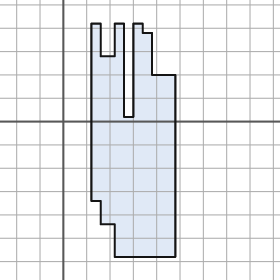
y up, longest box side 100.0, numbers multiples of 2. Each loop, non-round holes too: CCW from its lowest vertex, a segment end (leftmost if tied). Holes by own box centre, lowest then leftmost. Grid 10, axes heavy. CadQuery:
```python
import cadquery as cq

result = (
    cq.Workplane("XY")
    .moveTo(22.0, -58.0)
    .lineTo(48.0, -58.0)
    .lineTo(48.0, 20.0)
    .lineTo(38.0, 20.0)
    .lineTo(38.0, 38.0)
    .lineTo(34.0, 38.0)
    .lineTo(34.0, 42.0)
    .lineTo(30.0, 42.0)
    .lineTo(30.0, 2.0)
    .lineTo(26.0, 2.0)
    .lineTo(26.0, 42.0)
    .lineTo(22.0, 42.0)
    .lineTo(22.0, 28.0)
    .lineTo(16.0, 28.0)
    .lineTo(16.0, 42.0)
    .lineTo(12.0, 42.0)
    .lineTo(12.0, -34.0)
    .lineTo(16.0, -34.0)
    .lineTo(16.0, -44.0)
    .lineTo(22.0, -44.0)
    .close()
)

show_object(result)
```